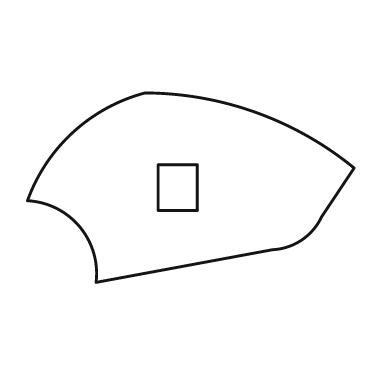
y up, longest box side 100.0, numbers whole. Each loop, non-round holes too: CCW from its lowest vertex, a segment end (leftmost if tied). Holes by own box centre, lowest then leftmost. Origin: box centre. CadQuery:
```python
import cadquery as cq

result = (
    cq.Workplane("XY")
    .moveTo(-29.0, -29.0)
    .lineTo(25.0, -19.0)
    .threePointArc((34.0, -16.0), (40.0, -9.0))
    .lineTo(50.0, 6.0)
    .threePointArc((20.0, 23.0), (-14.0, 29.0))
    .threePointArc((-36.0, 17.0), (-50.0, -4.0))
    .threePointArc((-34.0, -12.0), (-29.0, -29.0))
    .close()
    .moveTo(-10.0, -7.0)
    .lineTo(2.0, -7.0)
    .lineTo(2.0, 7.0)
    .lineTo(-10.0, 7.0)
    .close()
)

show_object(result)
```